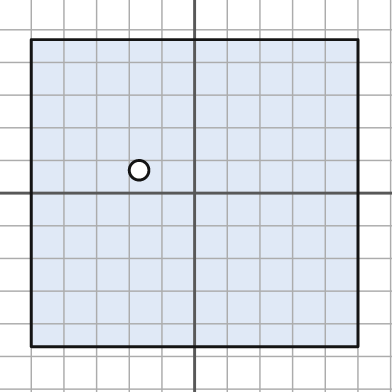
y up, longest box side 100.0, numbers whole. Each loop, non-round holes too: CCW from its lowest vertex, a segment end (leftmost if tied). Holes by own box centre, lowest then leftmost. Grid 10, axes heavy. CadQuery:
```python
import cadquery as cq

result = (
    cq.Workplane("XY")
    .moveTo(-50.0, -47.0)
    .lineTo(50.0, -47.0)
    .lineTo(50.0, 47.0)
    .lineTo(-50.0, 47.0)
    .close()
    .moveTo(-17.0, 7.0)
    .circle(3.0)
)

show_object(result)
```